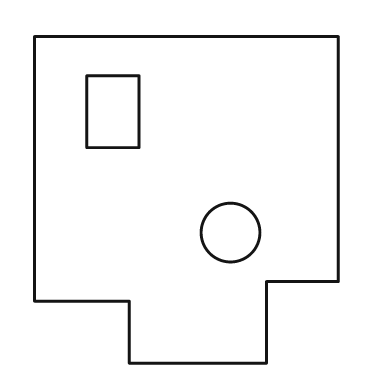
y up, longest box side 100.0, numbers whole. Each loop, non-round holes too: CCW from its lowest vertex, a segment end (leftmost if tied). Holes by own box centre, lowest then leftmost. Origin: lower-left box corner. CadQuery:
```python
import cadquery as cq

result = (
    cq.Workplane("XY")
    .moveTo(29.0, 0.0)
    .lineTo(71.0, 0.0)
    .lineTo(71.0, 25.0)
    .lineTo(93.0, 25.0)
    .lineTo(93.0, 100.0)
    .lineTo(0.0, 100.0)
    .lineTo(0.0, 19.0)
    .lineTo(29.0, 19.0)
    .close()
    .moveTo(60.0, 40.0)
    .circle(9.0)
    .moveTo(16.0, 66.0)
    .lineTo(32.0, 66.0)
    .lineTo(32.0, 88.0)
    .lineTo(16.0, 88.0)
    .close()
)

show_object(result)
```